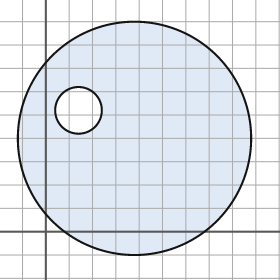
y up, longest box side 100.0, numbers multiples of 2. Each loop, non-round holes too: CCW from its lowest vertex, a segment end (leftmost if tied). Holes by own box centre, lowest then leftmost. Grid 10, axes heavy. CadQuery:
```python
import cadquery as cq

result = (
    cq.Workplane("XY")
    .moveTo(38.0, 40.0)
    .circle(50.0)
    .moveTo(14.0, 52.0)
    .circle(10.0)
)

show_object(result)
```